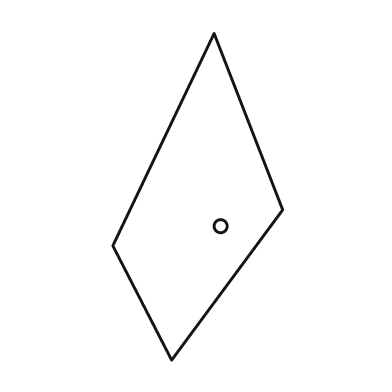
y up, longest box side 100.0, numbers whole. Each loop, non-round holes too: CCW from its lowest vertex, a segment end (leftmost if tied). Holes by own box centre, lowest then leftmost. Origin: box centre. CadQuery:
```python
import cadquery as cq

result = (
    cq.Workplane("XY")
    .moveTo(-8.0, -50.0)
    .lineTo(26.0, -4.0)
    .lineTo(5.0, 50.0)
    .lineTo(-26.0, -15.0)
    .close()
    .moveTo(7.0, -9.0)
    .circle(2.0)
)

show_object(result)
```